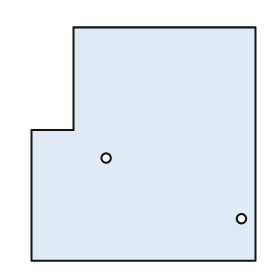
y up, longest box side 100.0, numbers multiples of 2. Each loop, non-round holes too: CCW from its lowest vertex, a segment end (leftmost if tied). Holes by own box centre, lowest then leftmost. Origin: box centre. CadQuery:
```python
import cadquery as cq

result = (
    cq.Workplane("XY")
    .moveTo(-48.0, -50.0)
    .lineTo(48.0, -50.0)
    .lineTo(48.0, 50.0)
    .lineTo(-30.0, 50.0)
    .lineTo(-30.0, 6.0)
    .lineTo(-48.0, 6.0)
    .close()
    .moveTo(42.0, -32.0)
    .circle(2.0)
    .moveTo(-16.0, -6.0)
    .circle(2.0)
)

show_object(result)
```